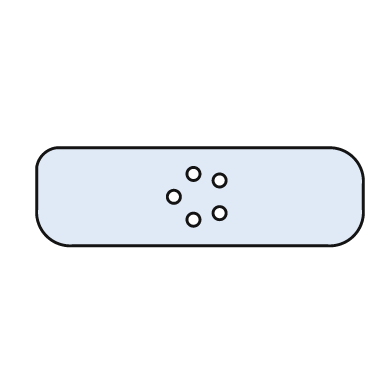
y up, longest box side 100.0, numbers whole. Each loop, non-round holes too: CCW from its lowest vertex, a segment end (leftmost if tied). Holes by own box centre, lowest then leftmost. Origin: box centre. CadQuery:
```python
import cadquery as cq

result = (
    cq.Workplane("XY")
    .moveTo(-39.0, -15.0)
    .lineTo(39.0, -15.0)
    .threePointArc((47.0, -12.0), (50.0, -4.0))
    .lineTo(50.0, 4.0)
    .threePointArc((47.0, 12.0), (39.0, 15.0))
    .lineTo(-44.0, 15.0)
    .threePointArc((-48.0, 13.0), (-50.0, 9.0))
    .lineTo(-50.0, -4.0)
    .threePointArc((-47.0, -12.0), (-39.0, -15.0))
    .close()
    .moveTo(-2.0, -7.0)
    .circle(2.0)
    .moveTo(6.0, -5.0)
    .circle(2.0)
    .moveTo(-8.0, 0.0)
    .circle(2.0)
    .moveTo(6.0, 5.0)
    .circle(2.0)
    .moveTo(-2.0, 7.0)
    .circle(2.0)
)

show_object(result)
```